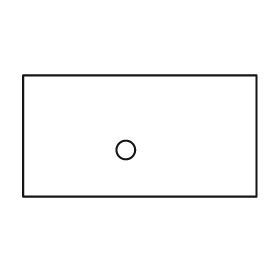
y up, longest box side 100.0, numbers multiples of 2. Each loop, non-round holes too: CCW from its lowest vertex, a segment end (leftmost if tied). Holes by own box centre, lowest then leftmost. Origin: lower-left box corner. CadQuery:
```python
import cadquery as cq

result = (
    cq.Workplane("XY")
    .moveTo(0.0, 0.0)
    .lineTo(100.0, 0.0)
    .lineTo(100.0, 52.0)
    .lineTo(0.0, 52.0)
    .close()
    .moveTo(44.0, 20.0)
    .circle(4.0)
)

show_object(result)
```